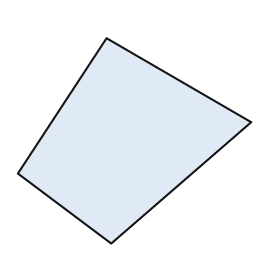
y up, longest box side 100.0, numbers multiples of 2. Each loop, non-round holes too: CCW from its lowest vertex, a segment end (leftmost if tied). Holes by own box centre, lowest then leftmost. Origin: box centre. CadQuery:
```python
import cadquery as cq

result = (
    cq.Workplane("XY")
    .moveTo(-10.0, -44.0)
    .lineTo(50.0, 8.0)
    .lineTo(-12.0, 44.0)
    .lineTo(-50.0, -14.0)
    .close()
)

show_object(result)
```